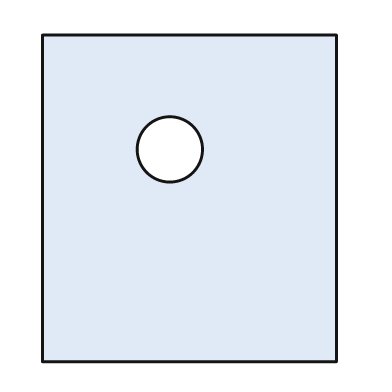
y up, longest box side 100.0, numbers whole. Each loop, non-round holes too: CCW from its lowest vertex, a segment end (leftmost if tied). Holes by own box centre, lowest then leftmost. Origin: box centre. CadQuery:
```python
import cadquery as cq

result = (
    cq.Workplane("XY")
    .moveTo(-45.0, -50.0)
    .lineTo(45.0, -50.0)
    .lineTo(45.0, 50.0)
    .lineTo(-45.0, 50.0)
    .close()
    .moveTo(-6.0, 15.0)
    .circle(10.0)
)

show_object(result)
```